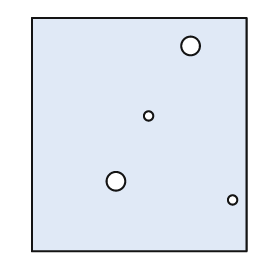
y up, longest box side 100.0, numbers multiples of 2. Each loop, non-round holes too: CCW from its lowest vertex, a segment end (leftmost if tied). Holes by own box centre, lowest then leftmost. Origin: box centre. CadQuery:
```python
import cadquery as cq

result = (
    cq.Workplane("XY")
    .moveTo(-46.0, -50.0)
    .lineTo(46.0, -50.0)
    .lineTo(46.0, 50.0)
    .lineTo(-46.0, 50.0)
    .close()
    .moveTo(40.0, -28.0)
    .circle(2.0)
    .moveTo(-10.0, -20.0)
    .circle(4.0)
    .moveTo(4.0, 8.0)
    .circle(2.0)
    .moveTo(22.0, 38.0)
    .circle(4.0)
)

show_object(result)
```